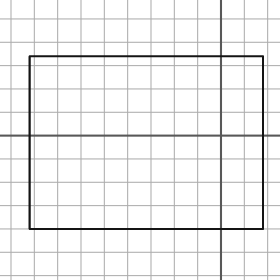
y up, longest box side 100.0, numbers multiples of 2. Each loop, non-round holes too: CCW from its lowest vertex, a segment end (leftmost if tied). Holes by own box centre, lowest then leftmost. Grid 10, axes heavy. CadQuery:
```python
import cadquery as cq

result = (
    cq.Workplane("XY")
    .moveTo(-82.0, -40.0)
    .lineTo(18.0, -40.0)
    .lineTo(18.0, 34.0)
    .lineTo(-82.0, 34.0)
    .close()
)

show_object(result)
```